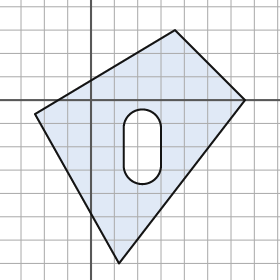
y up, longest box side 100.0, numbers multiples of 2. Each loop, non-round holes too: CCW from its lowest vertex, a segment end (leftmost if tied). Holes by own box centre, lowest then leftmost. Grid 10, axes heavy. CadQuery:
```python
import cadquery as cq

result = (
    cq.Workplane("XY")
    .moveTo(12.0, -70.0)
    .lineTo(66.0, 0.0)
    .lineTo(36.0, 30.0)
    .lineTo(-24.0, -6.0)
    .close()
    .moveTo(14.0, -28.0)
    .threePointArc((22.0, -36.0), (30.0, -28.0))
    .lineTo(30.0, -12.0)
    .threePointArc((22.0, -4.0), (14.0, -12.0))
    .close()
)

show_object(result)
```